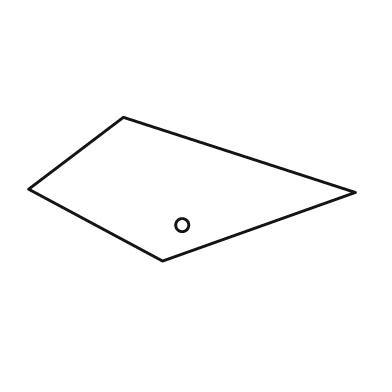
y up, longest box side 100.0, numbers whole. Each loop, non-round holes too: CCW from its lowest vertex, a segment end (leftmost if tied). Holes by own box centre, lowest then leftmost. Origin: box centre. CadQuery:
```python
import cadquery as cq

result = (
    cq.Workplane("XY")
    .moveTo(-9.0, -22.0)
    .lineTo(50.0, -1.0)
    .lineTo(-21.0, 22.0)
    .lineTo(-50.0, 0.0)
    .close()
    .moveTo(-3.0, -11.0)
    .circle(2.0)
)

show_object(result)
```